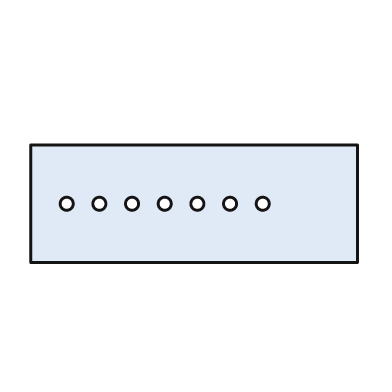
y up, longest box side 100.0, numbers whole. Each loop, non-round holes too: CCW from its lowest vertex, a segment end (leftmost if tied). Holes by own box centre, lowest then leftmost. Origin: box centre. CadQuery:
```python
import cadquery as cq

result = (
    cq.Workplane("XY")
    .moveTo(-50.0, -18.0)
    .lineTo(50.0, -18.0)
    .lineTo(50.0, 18.0)
    .lineTo(-50.0, 18.0)
    .close()
    .moveTo(-39.0, 0.0)
    .circle(2.0)
    .moveTo(-29.0, 0.0)
    .circle(2.0)
    .moveTo(-19.0, 0.0)
    .circle(2.0)
    .moveTo(-9.0, 0.0)
    .circle(2.0)
    .moveTo(1.0, 0.0)
    .circle(2.0)
    .moveTo(11.0, 0.0)
    .circle(2.0)
    .moveTo(21.0, 0.0)
    .circle(2.0)
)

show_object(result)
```